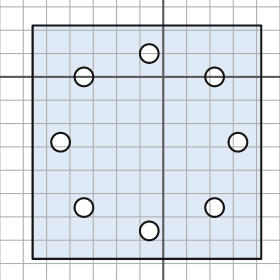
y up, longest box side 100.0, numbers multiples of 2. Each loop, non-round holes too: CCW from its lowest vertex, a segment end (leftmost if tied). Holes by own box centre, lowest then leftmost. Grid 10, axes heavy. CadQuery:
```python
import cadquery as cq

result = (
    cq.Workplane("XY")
    .moveTo(-56.0, -78.0)
    .lineTo(42.0, -78.0)
    .lineTo(42.0, 22.0)
    .lineTo(-56.0, 22.0)
    .close()
    .moveTo(-6.0, -66.0)
    .circle(4.0)
    .moveTo(-34.0, -56.0)
    .circle(4.0)
    .moveTo(22.0, -56.0)
    .circle(4.0)
    .moveTo(-44.0, -28.0)
    .circle(4.0)
    .moveTo(32.0, -28.0)
    .circle(4.0)
    .moveTo(-34.0, 0.0)
    .circle(4.0)
    .moveTo(22.0, 0.0)
    .circle(4.0)
    .moveTo(-6.0, 10.0)
    .circle(4.0)
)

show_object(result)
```